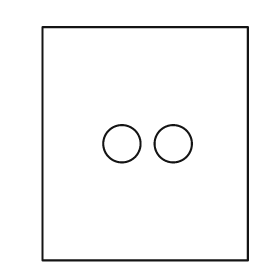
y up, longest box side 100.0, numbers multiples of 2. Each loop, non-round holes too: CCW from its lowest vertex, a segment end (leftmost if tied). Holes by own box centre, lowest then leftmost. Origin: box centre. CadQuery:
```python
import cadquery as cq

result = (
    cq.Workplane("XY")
    .moveTo(-44.0, -50.0)
    .lineTo(44.0, -50.0)
    .lineTo(44.0, 50.0)
    .lineTo(-44.0, 50.0)
    .close()
    .moveTo(-10.0, 0.0)
    .circle(8.0)
    .moveTo(12.0, 0.0)
    .circle(8.0)
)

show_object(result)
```